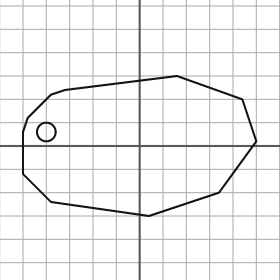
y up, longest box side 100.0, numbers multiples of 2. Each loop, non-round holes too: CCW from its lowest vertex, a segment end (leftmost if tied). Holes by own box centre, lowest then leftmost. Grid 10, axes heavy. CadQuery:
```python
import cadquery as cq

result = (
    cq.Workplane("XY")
    .moveTo(4.0, -30.0)
    .lineTo(34.0, -20.0)
    .lineTo(50.0, 2.0)
    .lineTo(44.0, 20.0)
    .lineTo(16.0, 30.0)
    .lineTo(-32.0, 24.0)
    .lineTo(-38.0, 22.0)
    .lineTo(-48.0, 12.0)
    .lineTo(-50.0, 6.0)
    .lineTo(-50.0, -12.0)
    .lineTo(-38.0, -24.0)
    .close()
    .moveTo(-40.0, 6.0)
    .circle(4.0)
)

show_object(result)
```